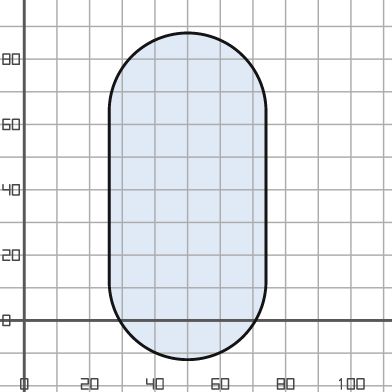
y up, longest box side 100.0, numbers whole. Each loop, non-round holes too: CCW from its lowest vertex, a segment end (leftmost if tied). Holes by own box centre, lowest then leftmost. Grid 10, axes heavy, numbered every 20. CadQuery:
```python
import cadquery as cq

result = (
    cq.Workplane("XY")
    .moveTo(26.0, 12.0)
    .threePointArc((50.0, -12.0), (74.0, 12.0))
    .lineTo(74.0, 64.0)
    .threePointArc((50.0, 88.0), (26.0, 64.0))
    .close()
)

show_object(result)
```